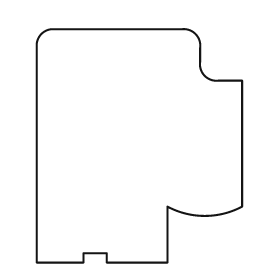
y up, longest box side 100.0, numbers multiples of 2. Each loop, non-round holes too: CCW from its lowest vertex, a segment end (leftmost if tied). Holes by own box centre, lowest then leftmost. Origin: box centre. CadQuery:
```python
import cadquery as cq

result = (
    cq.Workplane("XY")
    .moveTo(-44.0, -50.0)
    .lineTo(-24.0, -50.0)
    .lineTo(-24.0, -46.0)
    .lineTo(-14.0, -46.0)
    .lineTo(-14.0, -50.0)
    .lineTo(12.0, -50.0)
    .lineTo(12.0, -26.0)
    .threePointArc((28.0, -30.0), (44.0, -26.0))
    .lineTo(44.0, 28.0)
    .lineTo(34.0, 28.0)
    .threePointArc((28.0, 30.0), (26.0, 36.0))
    .lineTo(26.0, 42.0)
    .threePointArc((24.0, 48.0), (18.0, 50.0))
    .lineTo(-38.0, 50.0)
    .threePointArc((-42.0, 48.0), (-44.0, 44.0))
    .close()
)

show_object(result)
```